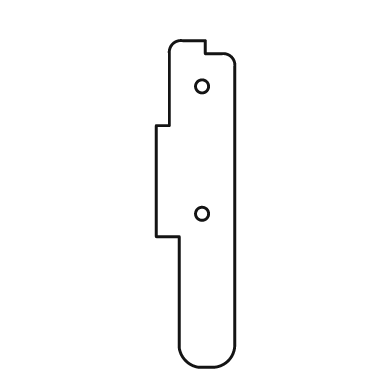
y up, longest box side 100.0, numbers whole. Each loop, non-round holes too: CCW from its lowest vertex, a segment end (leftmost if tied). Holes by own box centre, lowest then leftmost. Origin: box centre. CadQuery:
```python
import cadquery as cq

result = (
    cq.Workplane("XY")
    .moveTo(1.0, -50.0)
    .lineTo(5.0, -50.0)
    .threePointArc((10.0, -48.0), (12.0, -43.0))
    .lineTo(12.0, 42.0)
    .threePointArc((11.0, 45.0), (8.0, 46.0))
    .lineTo(3.0, 46.0)
    .lineTo(3.0, 50.0)
    .lineTo(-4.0, 50.0)
    .threePointArc((-7.0, 49.0), (-8.0, 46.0))
    .lineTo(-8.0, 24.0)
    .lineTo(-12.0, 24.0)
    .lineTo(-12.0, -10.0)
    .lineTo(-5.0, -10.0)
    .lineTo(-5.0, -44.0)
    .threePointArc((-3.0, -48.0), (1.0, -50.0))
    .close()
    .moveTo(2.0, -3.0)
    .circle(2.0)
    .moveTo(2.0, 36.0)
    .circle(2.0)
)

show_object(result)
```